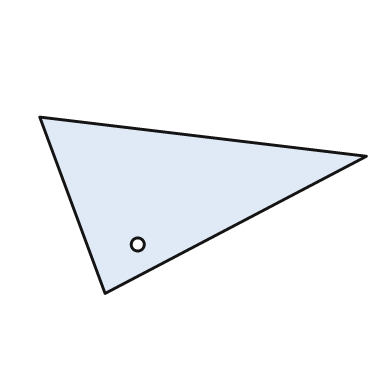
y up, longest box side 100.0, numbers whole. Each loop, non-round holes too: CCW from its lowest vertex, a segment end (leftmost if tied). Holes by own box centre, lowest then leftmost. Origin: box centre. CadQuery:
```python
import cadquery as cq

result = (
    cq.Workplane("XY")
    .moveTo(-30.0, -27.0)
    .lineTo(50.0, 15.0)
    .lineTo(-50.0, 27.0)
    .close()
    .moveTo(-20.0, -12.0)
    .circle(2.0)
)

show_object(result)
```